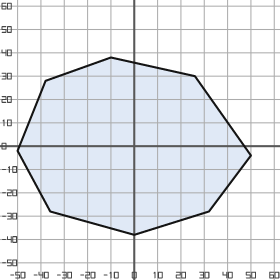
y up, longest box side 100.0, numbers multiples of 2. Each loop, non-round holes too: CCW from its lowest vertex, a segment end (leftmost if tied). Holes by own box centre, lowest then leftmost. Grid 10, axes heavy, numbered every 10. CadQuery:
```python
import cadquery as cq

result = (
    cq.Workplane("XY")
    .moveTo(0.0, -38.0)
    .lineTo(32.0, -28.0)
    .lineTo(50.0, -4.0)
    .lineTo(26.0, 30.0)
    .lineTo(-10.0, 38.0)
    .lineTo(-38.0, 28.0)
    .lineTo(-50.0, -2.0)
    .lineTo(-36.0, -28.0)
    .close()
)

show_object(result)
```